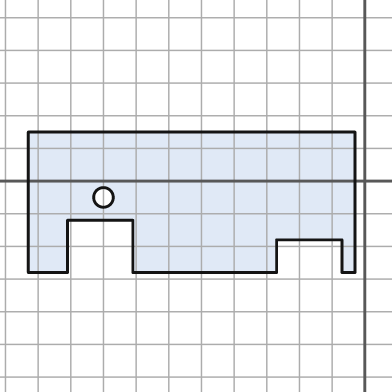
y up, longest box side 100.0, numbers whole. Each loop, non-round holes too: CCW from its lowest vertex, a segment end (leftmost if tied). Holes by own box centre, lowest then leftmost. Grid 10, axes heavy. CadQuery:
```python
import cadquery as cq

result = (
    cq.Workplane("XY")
    .moveTo(-103.0, -28.0)
    .lineTo(-91.0, -28.0)
    .lineTo(-91.0, -12.0)
    .lineTo(-71.0, -12.0)
    .lineTo(-71.0, -28.0)
    .lineTo(-27.0, -28.0)
    .lineTo(-27.0, -18.0)
    .lineTo(-7.0, -18.0)
    .lineTo(-7.0, -28.0)
    .lineTo(-3.0, -28.0)
    .lineTo(-3.0, 15.0)
    .lineTo(-103.0, 15.0)
    .close()
    .moveTo(-80.0, -5.0)
    .circle(3.0)
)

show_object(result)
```